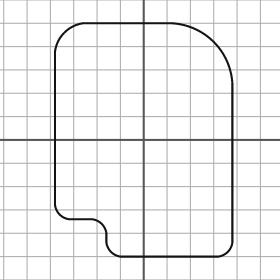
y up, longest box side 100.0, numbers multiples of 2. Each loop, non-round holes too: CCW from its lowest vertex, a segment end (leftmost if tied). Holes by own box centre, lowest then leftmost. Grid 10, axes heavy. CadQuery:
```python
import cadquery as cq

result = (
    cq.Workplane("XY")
    .moveTo(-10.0, -50.0)
    .lineTo(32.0, -50.0)
    .threePointArc((36.0, -48.0), (38.0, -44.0))
    .lineTo(38.0, 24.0)
    .threePointArc((30.0, 42.0), (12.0, 50.0))
    .lineTo(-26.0, 50.0)
    .threePointArc((-34.0, 46.0), (-38.0, 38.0))
    .lineTo(-38.0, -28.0)
    .threePointArc((-36.0, -32.0), (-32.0, -34.0))
    .lineTo(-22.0, -34.0)
    .threePointArc((-18.0, -36.0), (-16.0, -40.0))
    .lineTo(-16.0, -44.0)
    .threePointArc((-14.0, -48.0), (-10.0, -50.0))
    .close()
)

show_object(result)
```